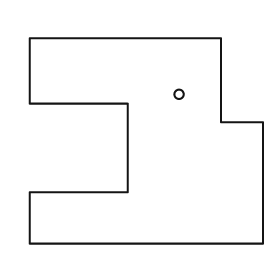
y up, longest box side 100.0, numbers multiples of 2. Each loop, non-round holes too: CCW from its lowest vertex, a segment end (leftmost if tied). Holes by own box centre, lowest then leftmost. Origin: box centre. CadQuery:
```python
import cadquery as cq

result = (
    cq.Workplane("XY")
    .moveTo(-50.0, -44.0)
    .lineTo(50.0, -44.0)
    .lineTo(50.0, 8.0)
    .lineTo(32.0, 8.0)
    .lineTo(32.0, 44.0)
    .lineTo(-50.0, 44.0)
    .lineTo(-50.0, 16.0)
    .lineTo(-8.0, 16.0)
    .lineTo(-8.0, -22.0)
    .lineTo(-50.0, -22.0)
    .close()
    .moveTo(14.0, 20.0)
    .circle(2.0)
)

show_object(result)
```